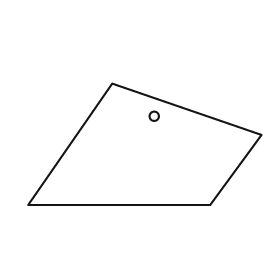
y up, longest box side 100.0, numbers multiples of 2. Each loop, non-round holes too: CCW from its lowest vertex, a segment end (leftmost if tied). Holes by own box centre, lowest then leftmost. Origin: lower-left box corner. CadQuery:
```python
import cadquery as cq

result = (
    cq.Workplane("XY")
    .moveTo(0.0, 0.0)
    .lineTo(78.0, 0.0)
    .lineTo(100.0, 30.0)
    .lineTo(36.0, 52.0)
    .close()
    .moveTo(54.0, 38.0)
    .circle(2.0)
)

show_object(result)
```